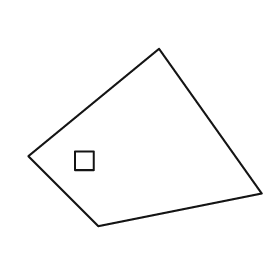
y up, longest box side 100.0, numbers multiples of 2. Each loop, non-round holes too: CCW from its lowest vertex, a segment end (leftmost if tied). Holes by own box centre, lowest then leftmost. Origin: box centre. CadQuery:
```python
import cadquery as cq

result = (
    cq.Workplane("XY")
    .moveTo(-20.0, -38.0)
    .lineTo(50.0, -24.0)
    .lineTo(6.0, 38.0)
    .lineTo(-50.0, -8.0)
    .close()
    .moveTo(-30.0, -14.0)
    .lineTo(-22.0, -14.0)
    .lineTo(-22.0, -6.0)
    .lineTo(-30.0, -6.0)
    .close()
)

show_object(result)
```